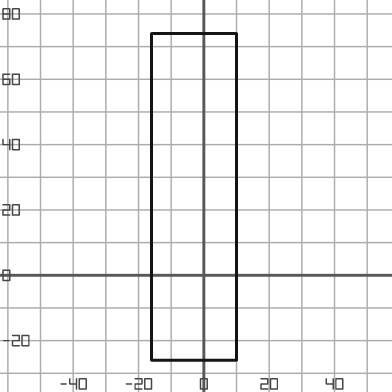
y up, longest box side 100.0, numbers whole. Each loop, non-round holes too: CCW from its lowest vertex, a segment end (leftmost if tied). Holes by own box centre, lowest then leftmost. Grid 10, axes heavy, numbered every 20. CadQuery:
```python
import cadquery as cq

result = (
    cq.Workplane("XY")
    .moveTo(-16.0, -26.0)
    .lineTo(10.0, -26.0)
    .lineTo(10.0, 74.0)
    .lineTo(-16.0, 74.0)
    .close()
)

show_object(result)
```